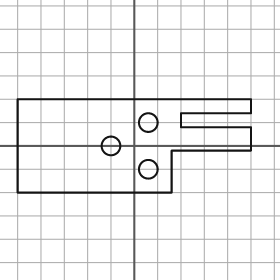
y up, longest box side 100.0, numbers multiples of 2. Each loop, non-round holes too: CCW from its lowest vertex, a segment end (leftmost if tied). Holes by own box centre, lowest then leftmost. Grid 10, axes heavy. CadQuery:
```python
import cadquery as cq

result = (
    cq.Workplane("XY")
    .moveTo(-50.0, -20.0)
    .lineTo(16.0, -20.0)
    .lineTo(16.0, -2.0)
    .lineTo(50.0, -2.0)
    .lineTo(50.0, 8.0)
    .lineTo(20.0, 8.0)
    .lineTo(20.0, 14.0)
    .lineTo(50.0, 14.0)
    .lineTo(50.0, 20.0)
    .lineTo(-50.0, 20.0)
    .close()
    .moveTo(6.0, -10.0)
    .circle(4.0)
    .moveTo(-10.0, 0.0)
    .circle(4.0)
    .moveTo(6.0, 10.0)
    .circle(4.0)
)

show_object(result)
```